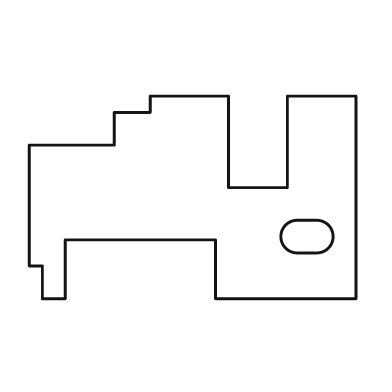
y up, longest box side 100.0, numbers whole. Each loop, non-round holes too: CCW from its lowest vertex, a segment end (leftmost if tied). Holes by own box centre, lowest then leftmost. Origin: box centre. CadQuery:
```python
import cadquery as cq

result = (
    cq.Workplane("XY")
    .moveTo(-46.0, -31.0)
    .lineTo(-39.0, -31.0)
    .lineTo(-39.0, -13.0)
    .lineTo(7.0, -13.0)
    .lineTo(7.0, -31.0)
    .lineTo(50.0, -31.0)
    .lineTo(50.0, 31.0)
    .lineTo(29.0, 31.0)
    .lineTo(29.0, 3.0)
    .lineTo(11.0, 3.0)
    .lineTo(11.0, 31.0)
    .lineTo(-13.0, 31.0)
    .lineTo(-13.0, 26.0)
    .lineTo(-24.0, 26.0)
    .lineTo(-24.0, 16.0)
    .lineTo(-50.0, 16.0)
    .lineTo(-50.0, -21.0)
    .lineTo(-46.0, -21.0)
    .close()
    .moveTo(32.0, -17.0)
    .lineTo(38.0, -17.0)
    .threePointArc((43.0, -12.0), (38.0, -7.0))
    .lineTo(32.0, -7.0)
    .threePointArc((27.0, -12.0), (32.0, -17.0))
    .close()
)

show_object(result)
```